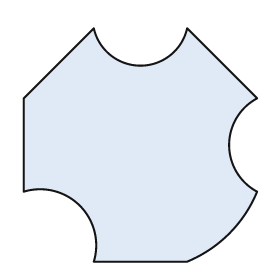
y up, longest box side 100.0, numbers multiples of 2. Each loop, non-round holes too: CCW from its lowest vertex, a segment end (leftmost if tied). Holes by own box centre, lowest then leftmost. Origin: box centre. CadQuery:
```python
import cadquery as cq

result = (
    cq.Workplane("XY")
    .moveTo(-20.0, -50.0)
    .lineTo(20.0, -50.0)
    .threePointArc((38.0, -38.0), (50.0, -20.0))
    .threePointArc((38.0, 0.0), (50.0, 20.0))
    .lineTo(20.0, 50.0)
    .threePointArc((0.0, 34.0), (-20.0, 50.0))
    .lineTo(-50.0, 20.0)
    .lineTo(-50.0, -20.0)
    .threePointArc((-26.0, -26.0), (-20.0, -50.0))
    .close()
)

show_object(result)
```